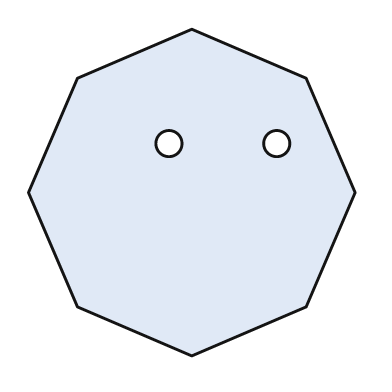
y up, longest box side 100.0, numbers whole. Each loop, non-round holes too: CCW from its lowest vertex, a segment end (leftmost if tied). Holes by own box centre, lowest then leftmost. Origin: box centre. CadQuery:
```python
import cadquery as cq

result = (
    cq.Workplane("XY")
    .moveTo(0.0, -50.0)
    .lineTo(35.0, -35.0)
    .lineTo(50.0, 0.0)
    .lineTo(35.0, 35.0)
    .lineTo(0.0, 50.0)
    .lineTo(-35.0, 35.0)
    .lineTo(-50.0, 0.0)
    .lineTo(-35.0, -35.0)
    .close()
    .moveTo(-7.0, 15.0)
    .circle(4.0)
    .moveTo(26.0, 15.0)
    .circle(4.0)
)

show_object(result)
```